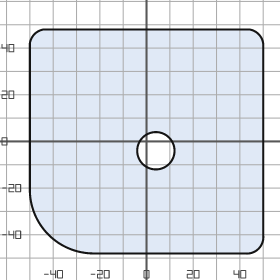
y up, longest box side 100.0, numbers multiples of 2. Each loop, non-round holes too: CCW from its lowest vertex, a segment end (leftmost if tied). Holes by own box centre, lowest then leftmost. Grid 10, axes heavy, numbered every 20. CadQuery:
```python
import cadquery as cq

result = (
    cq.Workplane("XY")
    .moveTo(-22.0, -48.0)
    .lineTo(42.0, -48.0)
    .threePointArc((48.0, -46.0), (50.0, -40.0))
    .lineTo(50.0, 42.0)
    .threePointArc((48.0, 46.0), (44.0, 48.0))
    .lineTo(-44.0, 48.0)
    .threePointArc((-48.0, 46.0), (-50.0, 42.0))
    .lineTo(-50.0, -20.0)
    .threePointArc((-42.0, -40.0), (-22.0, -48.0))
    .close()
    .moveTo(4.0, -4.0)
    .circle(8.0)
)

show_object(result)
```